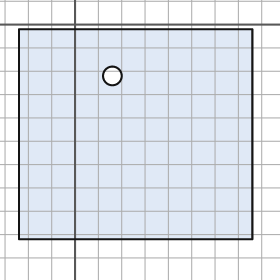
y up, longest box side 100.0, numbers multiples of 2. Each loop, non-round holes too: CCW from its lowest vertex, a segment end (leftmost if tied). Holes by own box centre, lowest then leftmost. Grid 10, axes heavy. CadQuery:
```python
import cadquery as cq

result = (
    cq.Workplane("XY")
    .moveTo(-24.0, -92.0)
    .lineTo(76.0, -92.0)
    .lineTo(76.0, -2.0)
    .lineTo(-24.0, -2.0)
    .close()
    .moveTo(16.0, -22.0)
    .circle(4.0)
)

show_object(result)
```